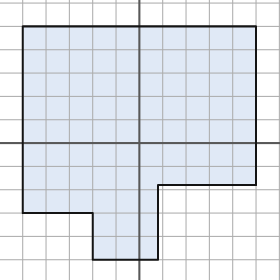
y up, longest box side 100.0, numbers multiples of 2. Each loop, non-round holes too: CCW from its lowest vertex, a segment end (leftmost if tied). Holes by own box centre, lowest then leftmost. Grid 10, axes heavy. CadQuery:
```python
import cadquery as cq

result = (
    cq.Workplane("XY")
    .moveTo(-20.0, -50.0)
    .lineTo(8.0, -50.0)
    .lineTo(8.0, -18.0)
    .lineTo(50.0, -18.0)
    .lineTo(50.0, 50.0)
    .lineTo(-50.0, 50.0)
    .lineTo(-50.0, -30.0)
    .lineTo(-20.0, -30.0)
    .close()
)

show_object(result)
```